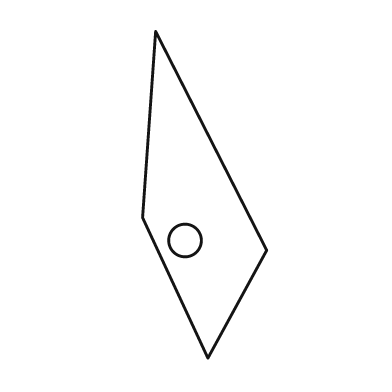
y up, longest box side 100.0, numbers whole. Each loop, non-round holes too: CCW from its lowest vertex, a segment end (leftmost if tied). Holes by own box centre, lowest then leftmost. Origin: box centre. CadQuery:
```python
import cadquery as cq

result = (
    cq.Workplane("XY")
    .moveTo(1.0, -50.0)
    .lineTo(19.0, -17.0)
    .lineTo(-15.0, 50.0)
    .lineTo(-19.0, -7.0)
    .close()
    .moveTo(-6.0, -14.0)
    .circle(5.0)
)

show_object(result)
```